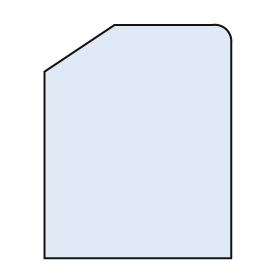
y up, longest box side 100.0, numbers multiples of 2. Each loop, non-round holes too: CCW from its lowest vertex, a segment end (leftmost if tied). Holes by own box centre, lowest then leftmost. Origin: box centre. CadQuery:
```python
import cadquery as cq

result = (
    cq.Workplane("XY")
    .moveTo(-40.0, -50.0)
    .lineTo(40.0, -50.0)
    .lineTo(40.0, 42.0)
    .threePointArc((38.0, 48.0), (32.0, 50.0))
    .lineTo(-10.0, 50.0)
    .lineTo(-40.0, 30.0)
    .close()
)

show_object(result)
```